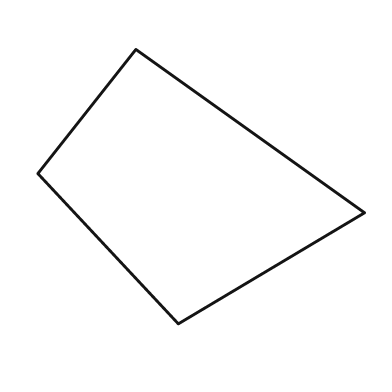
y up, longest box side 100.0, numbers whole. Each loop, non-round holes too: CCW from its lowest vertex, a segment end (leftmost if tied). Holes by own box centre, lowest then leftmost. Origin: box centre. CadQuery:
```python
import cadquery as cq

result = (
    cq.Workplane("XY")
    .moveTo(-7.0, -42.0)
    .lineTo(50.0, -8.0)
    .lineTo(-20.0, 42.0)
    .lineTo(-50.0, 4.0)
    .close()
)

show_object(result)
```